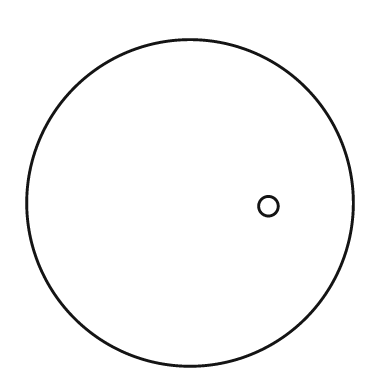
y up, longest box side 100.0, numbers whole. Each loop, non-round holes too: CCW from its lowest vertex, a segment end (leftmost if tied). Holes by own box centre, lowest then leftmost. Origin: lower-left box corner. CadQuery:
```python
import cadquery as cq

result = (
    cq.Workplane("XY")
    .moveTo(50.0, 50.0)
    .circle(50.0)
    .moveTo(74.0, 49.0)
    .circle(3.0)
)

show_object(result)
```